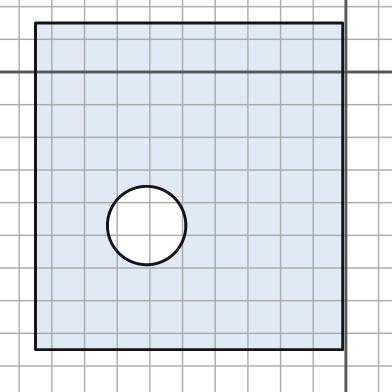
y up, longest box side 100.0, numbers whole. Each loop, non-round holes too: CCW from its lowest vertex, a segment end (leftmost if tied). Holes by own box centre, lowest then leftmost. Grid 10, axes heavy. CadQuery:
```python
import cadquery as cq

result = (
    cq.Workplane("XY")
    .moveTo(-95.0, -85.0)
    .lineTo(-1.0, -85.0)
    .lineTo(-1.0, 15.0)
    .lineTo(-95.0, 15.0)
    .close()
    .moveTo(-61.0, -47.0)
    .circle(12.0)
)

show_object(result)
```